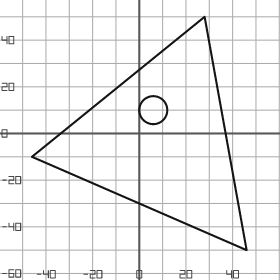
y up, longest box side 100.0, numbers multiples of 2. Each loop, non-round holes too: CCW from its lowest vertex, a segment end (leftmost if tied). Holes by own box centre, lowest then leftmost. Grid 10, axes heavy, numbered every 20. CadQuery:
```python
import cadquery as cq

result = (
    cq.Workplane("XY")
    .moveTo(46.0, -50.0)
    .lineTo(28.0, 50.0)
    .lineTo(-46.0, -10.0)
    .close()
    .moveTo(6.0, 10.0)
    .circle(6.0)
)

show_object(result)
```